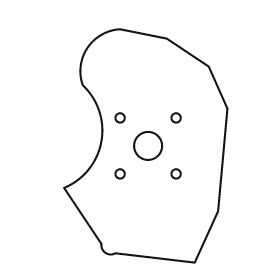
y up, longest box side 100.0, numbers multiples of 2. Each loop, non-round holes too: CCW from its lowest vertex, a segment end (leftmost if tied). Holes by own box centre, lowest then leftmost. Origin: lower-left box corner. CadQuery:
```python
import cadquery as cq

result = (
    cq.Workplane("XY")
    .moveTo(56.0, 0.0)
    .lineTo(66.0, 22.0)
    .lineTo(70.0, 66.0)
    .lineTo(62.0, 84.0)
    .lineTo(44.0, 96.0)
    .lineTo(24.0, 100.0)
    .threePointArc((10.0, 92.0), (8.0, 76.0))
    .threePointArc((16.0, 52.0), (0.0, 32.0))
    .lineTo(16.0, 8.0)
    .threePointArc((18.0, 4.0), (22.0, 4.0))
    .close()
    .moveTo(24.0, 38.0)
    .circle(2.0)
    .moveTo(48.0, 38.0)
    .circle(2.0)
    .moveTo(36.0, 50.0)
    .circle(6.0)
    .moveTo(24.0, 62.0)
    .circle(2.0)
    .moveTo(48.0, 62.0)
    .circle(2.0)
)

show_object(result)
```